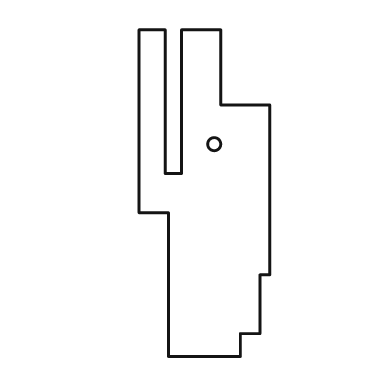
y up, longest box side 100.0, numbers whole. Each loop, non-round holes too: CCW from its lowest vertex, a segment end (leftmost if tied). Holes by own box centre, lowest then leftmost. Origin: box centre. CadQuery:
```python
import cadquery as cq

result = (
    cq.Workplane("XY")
    .moveTo(-11.0, -50.0)
    .lineTo(11.0, -50.0)
    .lineTo(11.0, -43.0)
    .lineTo(17.0, -43.0)
    .lineTo(17.0, -25.0)
    .lineTo(20.0, -25.0)
    .lineTo(20.0, 27.0)
    .lineTo(5.0, 27.0)
    .lineTo(5.0, 50.0)
    .lineTo(-7.0, 50.0)
    .lineTo(-7.0, 6.0)
    .lineTo(-12.0, 6.0)
    .lineTo(-12.0, 50.0)
    .lineTo(-20.0, 50.0)
    .lineTo(-20.0, -6.0)
    .lineTo(-11.0, -6.0)
    .close()
    .moveTo(3.0, 15.0)
    .circle(2.0)
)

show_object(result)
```